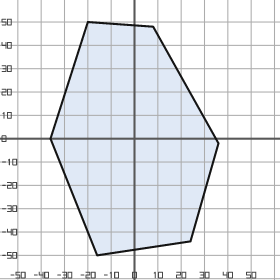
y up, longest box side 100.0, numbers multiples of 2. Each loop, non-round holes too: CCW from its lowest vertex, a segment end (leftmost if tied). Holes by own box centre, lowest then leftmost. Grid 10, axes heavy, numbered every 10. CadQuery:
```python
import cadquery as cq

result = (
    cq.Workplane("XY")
    .moveTo(-16.0, -50.0)
    .lineTo(24.0, -44.0)
    .lineTo(36.0, -2.0)
    .lineTo(8.0, 48.0)
    .lineTo(-20.0, 50.0)
    .lineTo(-36.0, 0.0)
    .close()
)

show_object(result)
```